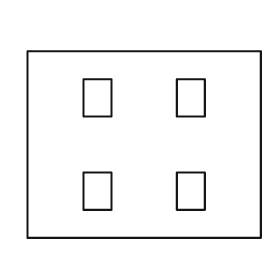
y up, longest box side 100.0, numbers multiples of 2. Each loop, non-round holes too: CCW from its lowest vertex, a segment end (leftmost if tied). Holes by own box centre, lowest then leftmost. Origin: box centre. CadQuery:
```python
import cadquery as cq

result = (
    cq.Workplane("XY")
    .moveTo(-50.0, -40.0)
    .lineTo(50.0, -40.0)
    .lineTo(50.0, 40.0)
    .lineTo(-50.0, 40.0)
    .close()
    .moveTo(-26.0, -28.0)
    .lineTo(-14.0, -28.0)
    .lineTo(-14.0, -12.0)
    .lineTo(-26.0, -12.0)
    .close()
    .moveTo(14.0, -28.0)
    .lineTo(26.0, -28.0)
    .lineTo(26.0, -12.0)
    .lineTo(14.0, -12.0)
    .close()
    .moveTo(-26.0, 12.0)
    .lineTo(-14.0, 12.0)
    .lineTo(-14.0, 28.0)
    .lineTo(-26.0, 28.0)
    .close()
    .moveTo(14.0, 12.0)
    .lineTo(26.0, 12.0)
    .lineTo(26.0, 28.0)
    .lineTo(14.0, 28.0)
    .close()
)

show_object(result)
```